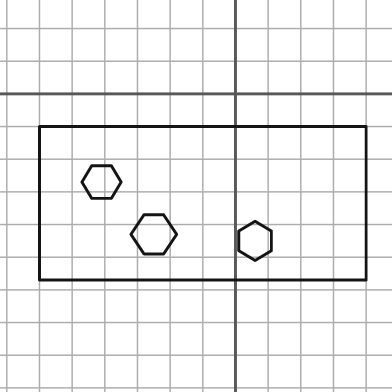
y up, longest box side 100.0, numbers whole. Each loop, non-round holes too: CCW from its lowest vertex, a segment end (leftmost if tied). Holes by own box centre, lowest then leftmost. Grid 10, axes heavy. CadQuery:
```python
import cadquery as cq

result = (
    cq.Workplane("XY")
    .moveTo(-60.0, -57.0)
    .lineTo(40.0, -57.0)
    .lineTo(40.0, -10.0)
    .lineTo(-60.0, -10.0)
    .close()
    .moveTo(6.0, -51.0)
    .lineTo(11.0, -48.0)
    .lineTo(11.0, -42.0)
    .lineTo(6.0, -39.0)
    .lineTo(1.0, -42.0)
    .lineTo(1.0, -48.0)
    .close()
    .moveTo(-28.0, -49.0)
    .lineTo(-22.0, -49.0)
    .lineTo(-18.0, -43.0)
    .lineTo(-22.0, -37.0)
    .lineTo(-28.0, -37.0)
    .lineTo(-32.0, -43.0)
    .close()
    .moveTo(-44.0, -32.0)
    .lineTo(-38.0, -32.0)
    .lineTo(-35.0, -27.0)
    .lineTo(-38.0, -22.0)
    .lineTo(-44.0, -22.0)
    .lineTo(-47.0, -27.0)
    .close()
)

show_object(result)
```